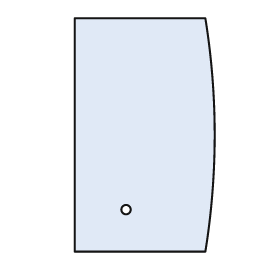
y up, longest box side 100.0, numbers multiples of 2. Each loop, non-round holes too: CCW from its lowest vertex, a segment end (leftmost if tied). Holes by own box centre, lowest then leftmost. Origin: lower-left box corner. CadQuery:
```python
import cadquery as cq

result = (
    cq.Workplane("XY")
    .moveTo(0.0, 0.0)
    .lineTo(56.0, 0.0)
    .threePointArc((60.0, 50.0), (56.0, 100.0))
    .lineTo(0.0, 100.0)
    .close()
    .moveTo(22.0, 18.0)
    .circle(2.0)
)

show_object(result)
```